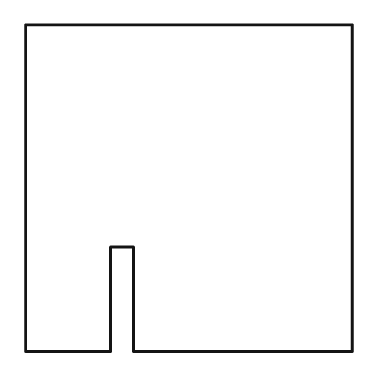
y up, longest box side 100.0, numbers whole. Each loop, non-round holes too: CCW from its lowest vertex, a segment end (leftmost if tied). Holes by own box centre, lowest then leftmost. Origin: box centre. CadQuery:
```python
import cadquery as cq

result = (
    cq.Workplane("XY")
    .moveTo(-50.0, -50.0)
    .lineTo(-24.0, -50.0)
    .lineTo(-24.0, -18.0)
    .lineTo(-17.0, -18.0)
    .lineTo(-17.0, -50.0)
    .lineTo(50.0, -50.0)
    .lineTo(50.0, 50.0)
    .lineTo(-50.0, 50.0)
    .close()
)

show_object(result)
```